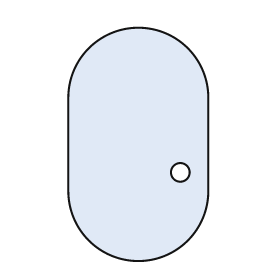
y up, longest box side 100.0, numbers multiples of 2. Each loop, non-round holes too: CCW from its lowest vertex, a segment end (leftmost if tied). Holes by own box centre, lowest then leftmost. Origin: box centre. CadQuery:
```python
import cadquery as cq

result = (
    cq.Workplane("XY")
    .moveTo(-30.0, -20.0)
    .threePointArc((0.0, -50.0), (30.0, -20.0))
    .lineTo(30.0, 20.0)
    .threePointArc((0.0, 50.0), (-30.0, 20.0))
    .close()
    .moveTo(18.0, -12.0)
    .circle(4.0)
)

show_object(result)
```